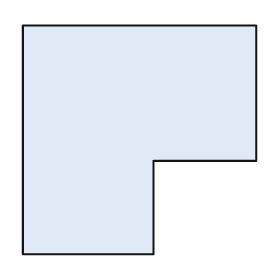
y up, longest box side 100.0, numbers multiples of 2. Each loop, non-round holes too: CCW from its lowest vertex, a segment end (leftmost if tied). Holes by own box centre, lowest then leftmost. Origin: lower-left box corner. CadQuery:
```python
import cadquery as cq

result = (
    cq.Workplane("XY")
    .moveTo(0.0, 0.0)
    .lineTo(56.0, 0.0)
    .lineTo(56.0, 40.0)
    .lineTo(100.0, 40.0)
    .lineTo(100.0, 98.0)
    .lineTo(0.0, 98.0)
    .close()
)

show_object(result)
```